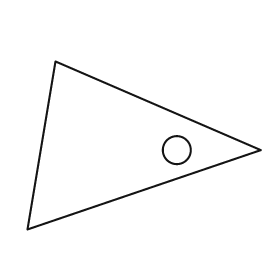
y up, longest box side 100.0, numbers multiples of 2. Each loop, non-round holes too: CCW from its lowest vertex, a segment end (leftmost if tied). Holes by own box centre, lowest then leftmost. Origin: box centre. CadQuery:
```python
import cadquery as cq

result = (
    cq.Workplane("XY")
    .moveTo(-50.0, -36.0)
    .lineTo(50.0, -2.0)
    .lineTo(-38.0, 36.0)
    .close()
    .moveTo(14.0, -2.0)
    .circle(6.0)
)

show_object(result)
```